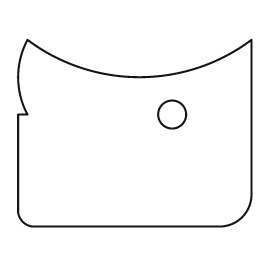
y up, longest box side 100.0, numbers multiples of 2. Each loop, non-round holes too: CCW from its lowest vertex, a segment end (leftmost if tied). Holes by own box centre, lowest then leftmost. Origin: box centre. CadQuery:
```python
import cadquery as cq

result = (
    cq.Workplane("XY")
    .moveTo(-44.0, -40.0)
    .lineTo(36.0, -40.0)
    .threePointArc((46.0, -36.0), (50.0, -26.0))
    .lineTo(50.0, 40.0)
    .threePointArc((2.0, 24.0), (-46.0, 40.0))
    .threePointArc((-50.0, 24.0), (-46.0, 8.0))
    .lineTo(-50.0, 8.0)
    .lineTo(-50.0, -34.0)
    .threePointArc((-48.0, -38.0), (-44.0, -40.0))
    .close()
    .moveTo(16.0, 8.0)
    .circle(6.0)
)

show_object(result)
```